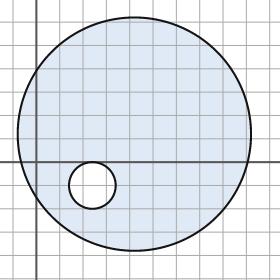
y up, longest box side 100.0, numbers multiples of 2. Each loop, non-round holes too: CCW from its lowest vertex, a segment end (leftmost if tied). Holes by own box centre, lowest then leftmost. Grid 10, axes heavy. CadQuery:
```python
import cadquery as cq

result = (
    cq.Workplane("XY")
    .moveTo(42.0, 12.0)
    .circle(50.0)
    .moveTo(24.0, -10.0)
    .circle(10.0)
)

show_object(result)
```